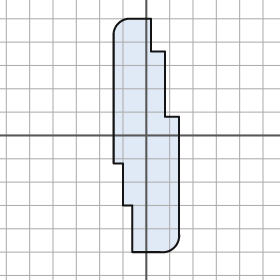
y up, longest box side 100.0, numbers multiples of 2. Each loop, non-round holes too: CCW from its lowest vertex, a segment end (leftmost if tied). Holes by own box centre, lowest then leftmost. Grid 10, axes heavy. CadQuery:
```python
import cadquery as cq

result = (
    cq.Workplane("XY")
    .moveTo(-6.0, -50.0)
    .lineTo(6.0, -50.0)
    .threePointArc((12.0, -48.0), (14.0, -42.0))
    .lineTo(14.0, 8.0)
    .lineTo(8.0, 8.0)
    .lineTo(8.0, 36.0)
    .lineTo(2.0, 36.0)
    .lineTo(2.0, 50.0)
    .lineTo(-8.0, 50.0)
    .threePointArc((-12.0, 48.0), (-14.0, 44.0))
    .lineTo(-14.0, -12.0)
    .lineTo(-10.0, -12.0)
    .lineTo(-10.0, -30.0)
    .lineTo(-6.0, -30.0)
    .close()
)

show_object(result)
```